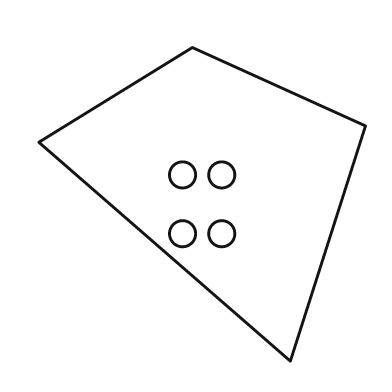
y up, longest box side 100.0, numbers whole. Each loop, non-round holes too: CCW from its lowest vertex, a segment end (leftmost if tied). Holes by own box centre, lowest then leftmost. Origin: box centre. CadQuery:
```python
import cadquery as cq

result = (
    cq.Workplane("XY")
    .moveTo(27.0, -48.0)
    .lineTo(50.0, 24.0)
    .lineTo(-3.0, 48.0)
    .lineTo(-50.0, 19.0)
    .close()
    .moveTo(-6.0, -9.0)
    .circle(4.0)
    .moveTo(6.0, -9.0)
    .circle(4.0)
    .moveTo(-6.0, 9.0)
    .circle(4.0)
    .moveTo(6.0, 9.0)
    .circle(4.0)
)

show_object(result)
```